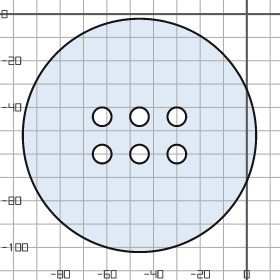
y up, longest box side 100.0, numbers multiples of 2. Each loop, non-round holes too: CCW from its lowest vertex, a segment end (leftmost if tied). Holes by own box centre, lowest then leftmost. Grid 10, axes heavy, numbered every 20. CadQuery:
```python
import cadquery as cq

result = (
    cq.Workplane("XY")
    .moveTo(-46.0, -52.0)
    .circle(50.0)
    .moveTo(-62.0, -60.0)
    .circle(4.0)
    .moveTo(-46.0, -60.0)
    .circle(4.0)
    .moveTo(-30.0, -60.0)
    .circle(4.0)
    .moveTo(-62.0, -44.0)
    .circle(4.0)
    .moveTo(-46.0, -44.0)
    .circle(4.0)
    .moveTo(-30.0, -44.0)
    .circle(4.0)
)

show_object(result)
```